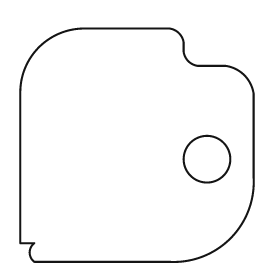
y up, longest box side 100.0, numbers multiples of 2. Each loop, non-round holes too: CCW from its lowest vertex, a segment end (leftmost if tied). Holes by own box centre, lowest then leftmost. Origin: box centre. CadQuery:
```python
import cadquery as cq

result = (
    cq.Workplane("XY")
    .moveTo(-44.0, -50.0)
    .lineTo(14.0, -50.0)
    .threePointArc((40.0, -40.0), (50.0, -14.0))
    .lineTo(50.0, 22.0)
    .threePointArc((46.0, 30.0), (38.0, 34.0))
    .lineTo(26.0, 34.0)
    .threePointArc((22.0, 36.0), (20.0, 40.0))
    .lineTo(20.0, 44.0)
    .threePointArc((18.0, 48.0), (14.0, 50.0))
    .lineTo(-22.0, 50.0)
    .threePointArc((-42.0, 42.0), (-50.0, 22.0))
    .lineTo(-50.0, -42.0)
    .lineTo(-44.0, -42.0)
    .threePointArc((-46.0, -46.0), (-44.0, -50.0))
    .close()
    .moveTo(30.0, -6.0)
    .circle(10.0)
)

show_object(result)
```